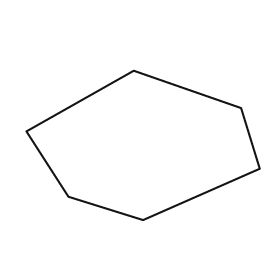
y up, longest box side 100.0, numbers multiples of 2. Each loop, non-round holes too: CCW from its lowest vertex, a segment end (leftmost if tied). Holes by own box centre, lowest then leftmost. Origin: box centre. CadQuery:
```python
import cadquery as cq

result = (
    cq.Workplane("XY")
    .moveTo(0.0, -32.0)
    .lineTo(50.0, -10.0)
    .lineTo(42.0, 16.0)
    .lineTo(-4.0, 32.0)
    .lineTo(-50.0, 6.0)
    .lineTo(-32.0, -22.0)
    .close()
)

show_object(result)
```